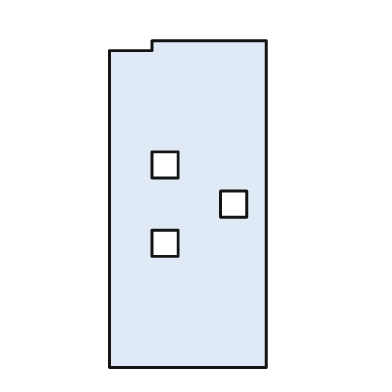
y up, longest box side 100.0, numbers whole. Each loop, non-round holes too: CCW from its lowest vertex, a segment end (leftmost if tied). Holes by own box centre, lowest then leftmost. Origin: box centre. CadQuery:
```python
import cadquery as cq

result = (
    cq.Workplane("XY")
    .moveTo(-24.0, -50.0)
    .lineTo(24.0, -50.0)
    .lineTo(24.0, 50.0)
    .lineTo(-11.0, 50.0)
    .lineTo(-11.0, 47.0)
    .lineTo(-24.0, 47.0)
    .close()
    .moveTo(-11.0, -16.0)
    .lineTo(-3.0, -16.0)
    .lineTo(-3.0, -8.0)
    .lineTo(-11.0, -8.0)
    .close()
    .moveTo(10.0, -4.0)
    .lineTo(18.0, -4.0)
    .lineTo(18.0, 4.0)
    .lineTo(10.0, 4.0)
    .close()
    .moveTo(-11.0, 8.0)
    .lineTo(-3.0, 8.0)
    .lineTo(-3.0, 16.0)
    .lineTo(-11.0, 16.0)
    .close()
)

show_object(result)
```